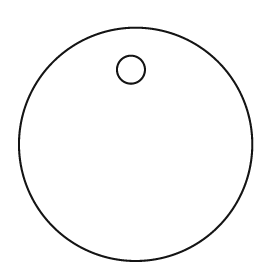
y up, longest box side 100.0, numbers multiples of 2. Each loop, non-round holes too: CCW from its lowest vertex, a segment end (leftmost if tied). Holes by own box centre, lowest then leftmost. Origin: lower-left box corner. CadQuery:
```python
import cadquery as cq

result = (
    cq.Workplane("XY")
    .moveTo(50.0, 50.0)
    .circle(50.0)
    .moveTo(48.0, 82.0)
    .circle(6.0)
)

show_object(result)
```